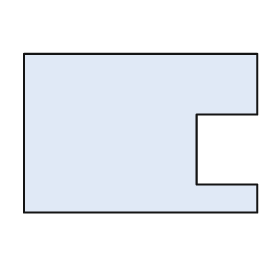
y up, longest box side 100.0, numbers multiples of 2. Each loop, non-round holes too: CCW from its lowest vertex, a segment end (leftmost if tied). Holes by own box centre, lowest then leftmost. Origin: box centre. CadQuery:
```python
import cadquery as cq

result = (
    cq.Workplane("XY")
    .moveTo(-50.0, -34.0)
    .lineTo(50.0, -34.0)
    .lineTo(50.0, -22.0)
    .lineTo(24.0, -22.0)
    .lineTo(24.0, 8.0)
    .lineTo(50.0, 8.0)
    .lineTo(50.0, 34.0)
    .lineTo(-50.0, 34.0)
    .close()
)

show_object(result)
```